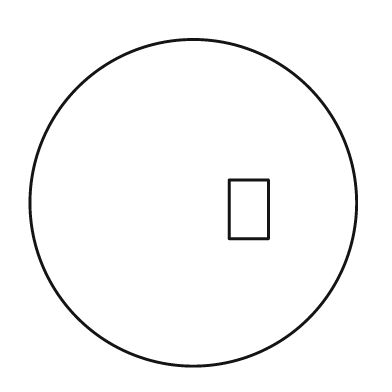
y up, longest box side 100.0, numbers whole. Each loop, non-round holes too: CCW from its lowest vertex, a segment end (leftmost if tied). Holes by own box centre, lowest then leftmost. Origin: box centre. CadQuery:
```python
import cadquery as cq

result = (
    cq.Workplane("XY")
    .moveTo(0.0, 0.0)
    .circle(50.0)
    .moveTo(11.0, -11.0)
    .lineTo(23.0, -11.0)
    .lineTo(23.0, 7.0)
    .lineTo(11.0, 7.0)
    .close()
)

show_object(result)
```